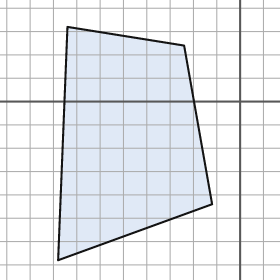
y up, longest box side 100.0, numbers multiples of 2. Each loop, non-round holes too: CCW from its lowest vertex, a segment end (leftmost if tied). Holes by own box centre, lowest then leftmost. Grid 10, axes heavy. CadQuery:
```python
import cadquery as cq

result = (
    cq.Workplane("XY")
    .moveTo(-78.0, -68.0)
    .lineTo(-12.0, -44.0)
    .lineTo(-24.0, 24.0)
    .lineTo(-74.0, 32.0)
    .close()
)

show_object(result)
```